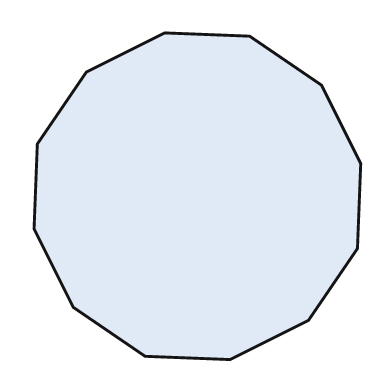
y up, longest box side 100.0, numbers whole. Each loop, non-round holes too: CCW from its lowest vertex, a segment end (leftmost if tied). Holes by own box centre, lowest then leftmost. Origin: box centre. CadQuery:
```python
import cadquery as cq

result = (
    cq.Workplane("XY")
    .moveTo(10.0, -50.0)
    .lineTo(34.0, -38.0)
    .lineTo(49.0, -16.0)
    .lineTo(50.0, 10.0)
    .lineTo(38.0, 34.0)
    .lineTo(16.0, 49.0)
    .lineTo(-10.0, 50.0)
    .lineTo(-34.0, 38.0)
    .lineTo(-49.0, 16.0)
    .lineTo(-50.0, -10.0)
    .lineTo(-38.0, -34.0)
    .lineTo(-16.0, -49.0)
    .close()
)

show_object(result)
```